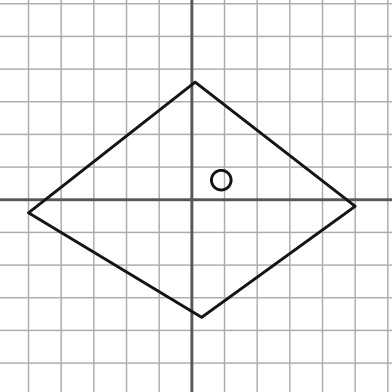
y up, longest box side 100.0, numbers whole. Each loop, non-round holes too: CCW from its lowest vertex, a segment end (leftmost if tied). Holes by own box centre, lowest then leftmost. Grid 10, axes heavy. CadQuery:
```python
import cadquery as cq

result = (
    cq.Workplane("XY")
    .moveTo(3.0, -36.0)
    .lineTo(50.0, -2.0)
    .lineTo(1.0, 36.0)
    .lineTo(-50.0, -4.0)
    .close()
    .moveTo(9.0, 6.0)
    .circle(3.0)
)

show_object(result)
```